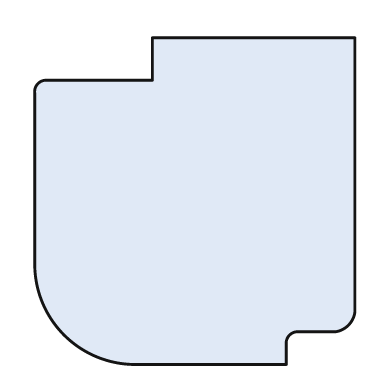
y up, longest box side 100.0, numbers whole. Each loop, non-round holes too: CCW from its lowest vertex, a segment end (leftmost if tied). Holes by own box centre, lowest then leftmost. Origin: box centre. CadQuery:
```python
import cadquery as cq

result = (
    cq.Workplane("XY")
    .moveTo(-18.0, -50.0)
    .lineTo(28.0, -50.0)
    .lineTo(28.0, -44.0)
    .threePointArc((29.0, -41.0), (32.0, -40.0))
    .lineTo(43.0, -40.0)
    .threePointArc((47.0, -38.0), (49.0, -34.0))
    .lineTo(49.0, 50.0)
    .lineTo(-13.0, 50.0)
    .lineTo(-13.0, 37.0)
    .lineTo(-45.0, 37.0)
    .threePointArc((-48.0, 36.0), (-49.0, 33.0))
    .lineTo(-49.0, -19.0)
    .threePointArc((-40.0, -41.0), (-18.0, -50.0))
    .close()
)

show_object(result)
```